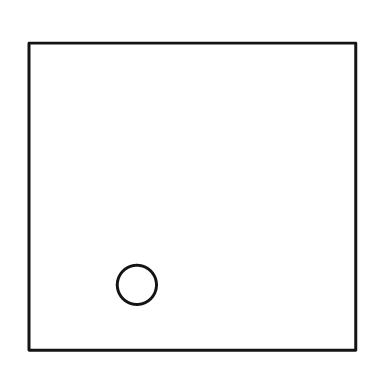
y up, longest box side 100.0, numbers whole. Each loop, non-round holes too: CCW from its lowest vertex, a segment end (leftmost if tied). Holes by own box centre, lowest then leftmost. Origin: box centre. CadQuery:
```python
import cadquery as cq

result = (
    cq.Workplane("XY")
    .moveTo(-50.0, -47.0)
    .lineTo(50.0, -47.0)
    .lineTo(50.0, 47.0)
    .lineTo(-50.0, 47.0)
    .close()
    .moveTo(-17.0, -27.0)
    .circle(6.0)
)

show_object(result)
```